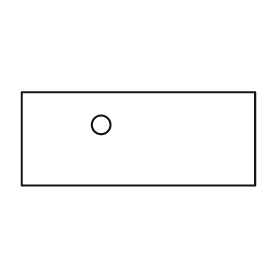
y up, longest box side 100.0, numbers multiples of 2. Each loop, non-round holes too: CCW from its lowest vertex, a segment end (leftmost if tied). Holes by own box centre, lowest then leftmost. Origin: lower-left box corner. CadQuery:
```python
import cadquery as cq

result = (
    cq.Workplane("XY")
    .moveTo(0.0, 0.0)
    .lineTo(100.0, 0.0)
    .lineTo(100.0, 40.0)
    .lineTo(0.0, 40.0)
    .close()
    .moveTo(34.0, 26.0)
    .circle(4.0)
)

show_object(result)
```